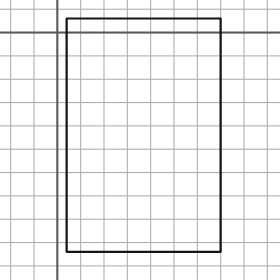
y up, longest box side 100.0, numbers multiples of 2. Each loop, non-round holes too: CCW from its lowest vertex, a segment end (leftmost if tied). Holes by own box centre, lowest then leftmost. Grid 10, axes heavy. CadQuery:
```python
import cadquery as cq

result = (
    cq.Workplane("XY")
    .moveTo(4.0, -94.0)
    .lineTo(70.0, -94.0)
    .lineTo(70.0, 6.0)
    .lineTo(4.0, 6.0)
    .close()
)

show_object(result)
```